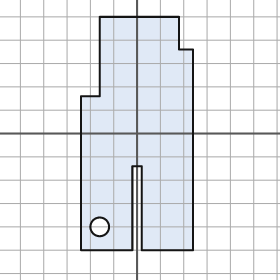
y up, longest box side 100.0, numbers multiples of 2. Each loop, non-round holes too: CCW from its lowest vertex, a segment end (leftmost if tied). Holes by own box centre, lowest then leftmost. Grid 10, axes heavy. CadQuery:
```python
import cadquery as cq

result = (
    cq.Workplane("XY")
    .moveTo(-24.0, -50.0)
    .lineTo(-2.0, -50.0)
    .lineTo(-2.0, -14.0)
    .lineTo(2.0, -14.0)
    .lineTo(2.0, -50.0)
    .lineTo(24.0, -50.0)
    .lineTo(24.0, 36.0)
    .lineTo(18.0, 36.0)
    .lineTo(18.0, 50.0)
    .lineTo(-16.0, 50.0)
    .lineTo(-16.0, 16.0)
    .lineTo(-24.0, 16.0)
    .close()
    .moveTo(-16.0, -40.0)
    .circle(4.0)
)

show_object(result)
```